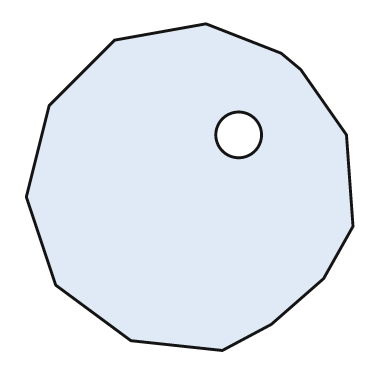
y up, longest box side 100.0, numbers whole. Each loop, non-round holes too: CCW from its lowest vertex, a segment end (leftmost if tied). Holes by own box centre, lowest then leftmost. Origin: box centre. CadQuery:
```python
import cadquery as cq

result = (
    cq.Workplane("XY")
    .moveTo(10.0, -50.0)
    .lineTo(25.0, -42.0)
    .lineTo(41.0, -28.0)
    .lineTo(50.0, -12.0)
    .lineTo(48.0, 16.0)
    .lineTo(34.0, 36.0)
    .lineTo(28.0, 41.0)
    .lineTo(5.0, 50.0)
    .lineTo(-23.0, 45.0)
    .lineTo(-43.0, 25.0)
    .lineTo(-50.0, -3.0)
    .lineTo(-41.0, -30.0)
    .lineTo(-18.0, -47.0)
    .close()
    .moveTo(15.0, 16.0)
    .circle(7.0)
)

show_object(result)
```